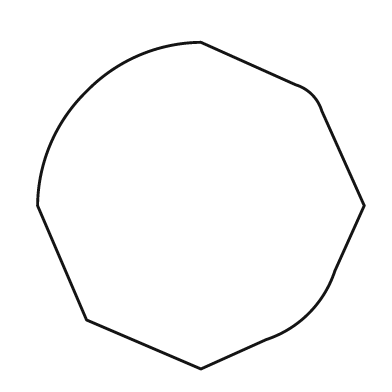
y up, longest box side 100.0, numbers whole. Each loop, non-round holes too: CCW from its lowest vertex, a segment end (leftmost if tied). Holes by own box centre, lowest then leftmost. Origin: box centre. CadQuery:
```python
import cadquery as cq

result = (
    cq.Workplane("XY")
    .moveTo(0.0, -50.0)
    .lineTo(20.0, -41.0)
    .threePointArc((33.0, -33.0), (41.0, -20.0))
    .lineTo(50.0, 0.0)
    .lineTo(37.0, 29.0)
    .threePointArc((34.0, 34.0), (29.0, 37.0))
    .lineTo(0.0, 50.0)
    .threePointArc((-19.0, 46.0), (-35.0, 35.0))
    .threePointArc((-46.0, 19.0), (-50.0, 0.0))
    .lineTo(-35.0, -35.0)
    .close()
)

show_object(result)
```